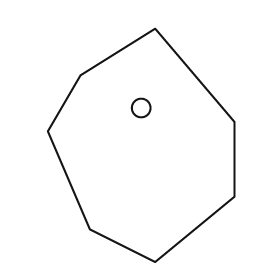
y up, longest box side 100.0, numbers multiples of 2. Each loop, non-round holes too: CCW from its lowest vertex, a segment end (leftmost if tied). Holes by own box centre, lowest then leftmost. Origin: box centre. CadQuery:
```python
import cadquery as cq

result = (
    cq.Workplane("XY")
    .moveTo(6.0, -50.0)
    .lineTo(40.0, -22.0)
    .lineTo(40.0, 10.0)
    .lineTo(6.0, 50.0)
    .lineTo(-26.0, 30.0)
    .lineTo(-40.0, 6.0)
    .lineTo(-22.0, -36.0)
    .close()
    .moveTo(0.0, 16.0)
    .circle(4.0)
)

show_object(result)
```